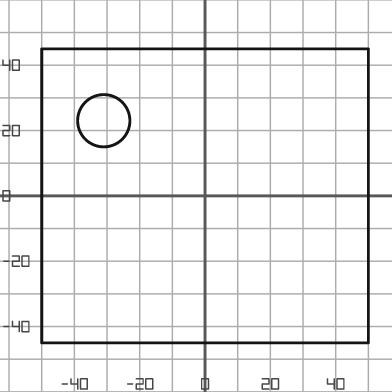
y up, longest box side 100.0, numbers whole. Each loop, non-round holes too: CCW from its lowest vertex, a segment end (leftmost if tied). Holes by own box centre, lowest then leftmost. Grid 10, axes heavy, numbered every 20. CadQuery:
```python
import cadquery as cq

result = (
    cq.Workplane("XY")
    .moveTo(-50.0, -45.0)
    .lineTo(50.0, -45.0)
    .lineTo(50.0, 45.0)
    .lineTo(-50.0, 45.0)
    .close()
    .moveTo(-31.0, 23.0)
    .circle(8.0)
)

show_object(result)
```